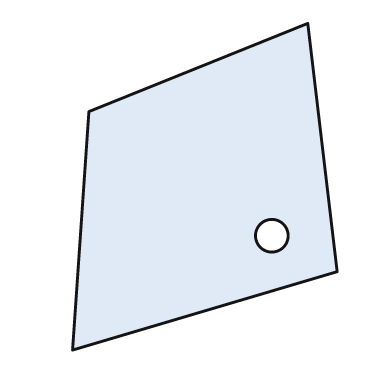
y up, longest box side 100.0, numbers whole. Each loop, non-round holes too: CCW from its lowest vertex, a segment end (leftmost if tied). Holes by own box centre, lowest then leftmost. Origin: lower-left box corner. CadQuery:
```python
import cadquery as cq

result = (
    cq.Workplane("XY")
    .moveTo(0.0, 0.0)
    .lineTo(81.0, 24.0)
    .lineTo(72.0, 100.0)
    .lineTo(5.0, 73.0)
    .close()
    .moveTo(61.0, 35.0)
    .circle(5.0)
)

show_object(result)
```